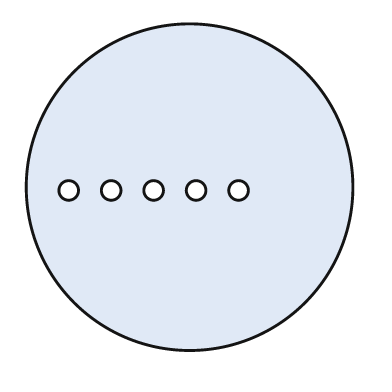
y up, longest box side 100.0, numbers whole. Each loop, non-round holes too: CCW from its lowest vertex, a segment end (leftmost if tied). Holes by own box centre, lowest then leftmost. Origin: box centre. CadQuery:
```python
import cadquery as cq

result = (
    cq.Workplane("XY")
    .moveTo(0.0, 0.0)
    .circle(50.0)
    .moveTo(-37.0, -1.0)
    .circle(3.0)
    .moveTo(-24.0, -1.0)
    .circle(3.0)
    .moveTo(-11.0, -1.0)
    .circle(3.0)
    .moveTo(2.0, -1.0)
    .circle(3.0)
    .moveTo(15.0, -1.0)
    .circle(3.0)
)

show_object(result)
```